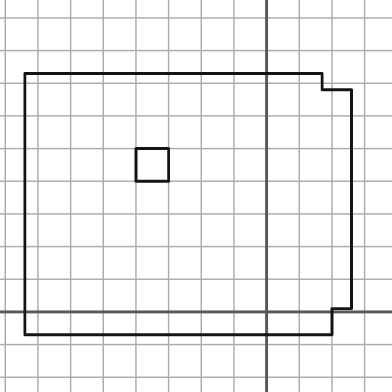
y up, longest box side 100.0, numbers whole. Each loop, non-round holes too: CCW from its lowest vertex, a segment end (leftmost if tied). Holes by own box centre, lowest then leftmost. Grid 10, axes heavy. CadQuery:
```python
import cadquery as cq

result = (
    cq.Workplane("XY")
    .moveTo(-74.0, -7.0)
    .lineTo(20.0, -7.0)
    .lineTo(20.0, 1.0)
    .lineTo(26.0, 1.0)
    .lineTo(26.0, 68.0)
    .lineTo(17.0, 68.0)
    .lineTo(17.0, 73.0)
    .lineTo(-74.0, 73.0)
    .close()
    .moveTo(-40.0, 40.0)
    .lineTo(-30.0, 40.0)
    .lineTo(-30.0, 50.0)
    .lineTo(-40.0, 50.0)
    .close()
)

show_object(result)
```